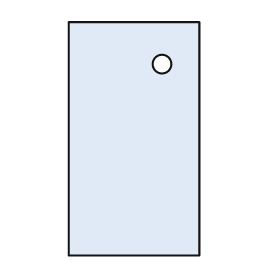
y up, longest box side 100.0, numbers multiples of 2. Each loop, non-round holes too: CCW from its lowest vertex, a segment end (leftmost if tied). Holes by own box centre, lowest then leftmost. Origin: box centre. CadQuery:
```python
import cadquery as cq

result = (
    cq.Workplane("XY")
    .moveTo(-28.0, -50.0)
    .lineTo(28.0, -50.0)
    .lineTo(28.0, 50.0)
    .lineTo(-28.0, 50.0)
    .close()
    .moveTo(12.0, 32.0)
    .circle(4.0)
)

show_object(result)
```